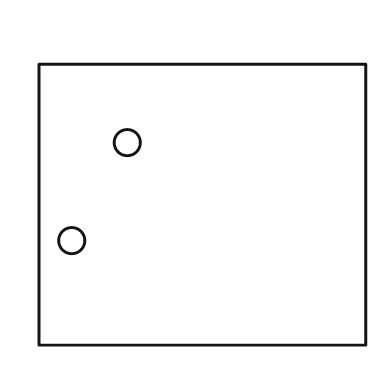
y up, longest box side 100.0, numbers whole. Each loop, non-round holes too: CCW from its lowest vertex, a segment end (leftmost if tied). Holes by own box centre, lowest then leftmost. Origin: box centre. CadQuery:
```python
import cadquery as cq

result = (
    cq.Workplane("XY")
    .moveTo(-50.0, -43.0)
    .lineTo(50.0, -43.0)
    .lineTo(50.0, 43.0)
    .lineTo(-50.0, 43.0)
    .close()
    .moveTo(-40.0, -11.0)
    .circle(4.0)
    .moveTo(-23.0, 19.0)
    .circle(4.0)
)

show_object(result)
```